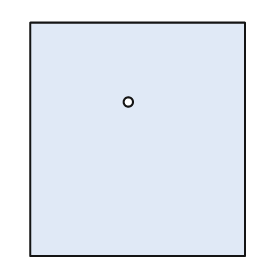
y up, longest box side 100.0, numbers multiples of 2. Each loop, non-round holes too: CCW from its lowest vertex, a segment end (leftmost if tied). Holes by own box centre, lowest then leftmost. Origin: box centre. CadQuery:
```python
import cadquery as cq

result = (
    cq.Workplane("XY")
    .moveTo(-46.0, -50.0)
    .lineTo(46.0, -50.0)
    .lineTo(46.0, 50.0)
    .lineTo(-46.0, 50.0)
    .close()
    .moveTo(-4.0, 16.0)
    .circle(2.0)
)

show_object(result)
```